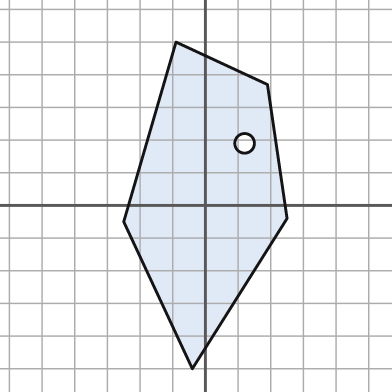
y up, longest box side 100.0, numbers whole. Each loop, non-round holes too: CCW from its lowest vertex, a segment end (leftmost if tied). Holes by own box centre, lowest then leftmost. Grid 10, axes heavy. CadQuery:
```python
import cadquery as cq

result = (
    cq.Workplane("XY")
    .moveTo(-4.0, -50.0)
    .lineTo(25.0, -4.0)
    .lineTo(19.0, 37.0)
    .lineTo(-9.0, 50.0)
    .lineTo(-25.0, -5.0)
    .close()
    .moveTo(12.0, 19.0)
    .circle(3.0)
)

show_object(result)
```